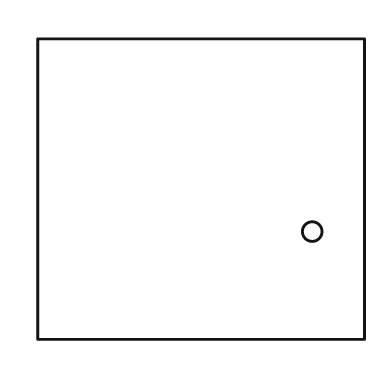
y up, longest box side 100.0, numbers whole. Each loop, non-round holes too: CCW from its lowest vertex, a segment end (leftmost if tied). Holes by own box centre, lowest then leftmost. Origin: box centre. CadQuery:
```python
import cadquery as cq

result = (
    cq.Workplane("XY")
    .moveTo(-50.0, -46.0)
    .lineTo(50.0, -46.0)
    .lineTo(50.0, 46.0)
    .lineTo(-50.0, 46.0)
    .close()
    .moveTo(34.0, -13.0)
    .circle(3.0)
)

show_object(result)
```